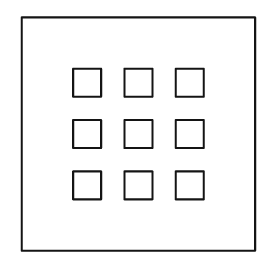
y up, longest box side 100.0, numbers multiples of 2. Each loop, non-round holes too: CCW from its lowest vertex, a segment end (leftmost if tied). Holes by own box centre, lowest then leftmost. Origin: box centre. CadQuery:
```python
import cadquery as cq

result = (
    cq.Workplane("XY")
    .moveTo(-50.0, -50.0)
    .lineTo(50.0, -50.0)
    .lineTo(50.0, 50.0)
    .lineTo(-50.0, 50.0)
    .close()
    .moveTo(-28.0, -28.0)
    .lineTo(-16.0, -28.0)
    .lineTo(-16.0, -16.0)
    .lineTo(-28.0, -16.0)
    .close()
    .moveTo(-6.0, -28.0)
    .lineTo(6.0, -28.0)
    .lineTo(6.0, -16.0)
    .lineTo(-6.0, -16.0)
    .close()
    .moveTo(16.0, -28.0)
    .lineTo(28.0, -28.0)
    .lineTo(28.0, -16.0)
    .lineTo(16.0, -16.0)
    .close()
    .moveTo(-28.0, -6.0)
    .lineTo(-16.0, -6.0)
    .lineTo(-16.0, 6.0)
    .lineTo(-28.0, 6.0)
    .close()
    .moveTo(-6.0, -6.0)
    .lineTo(6.0, -6.0)
    .lineTo(6.0, 6.0)
    .lineTo(-6.0, 6.0)
    .close()
    .moveTo(16.0, -6.0)
    .lineTo(28.0, -6.0)
    .lineTo(28.0, 6.0)
    .lineTo(16.0, 6.0)
    .close()
    .moveTo(-28.0, 16.0)
    .lineTo(-16.0, 16.0)
    .lineTo(-16.0, 28.0)
    .lineTo(-28.0, 28.0)
    .close()
    .moveTo(-6.0, 16.0)
    .lineTo(6.0, 16.0)
    .lineTo(6.0, 28.0)
    .lineTo(-6.0, 28.0)
    .close()
    .moveTo(16.0, 16.0)
    .lineTo(28.0, 16.0)
    .lineTo(28.0, 28.0)
    .lineTo(16.0, 28.0)
    .close()
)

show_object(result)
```